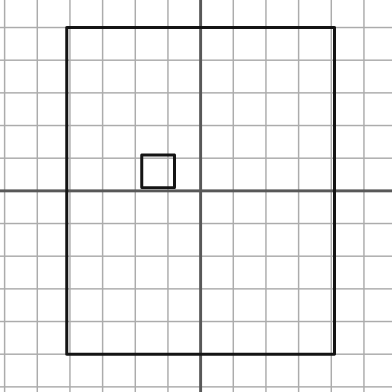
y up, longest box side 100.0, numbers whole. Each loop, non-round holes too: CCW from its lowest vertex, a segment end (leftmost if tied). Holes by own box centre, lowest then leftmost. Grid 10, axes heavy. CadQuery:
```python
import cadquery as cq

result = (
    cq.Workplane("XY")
    .moveTo(-41.0, -50.0)
    .lineTo(41.0, -50.0)
    .lineTo(41.0, 50.0)
    .lineTo(-41.0, 50.0)
    .close()
    .moveTo(-18.0, 1.0)
    .lineTo(-8.0, 1.0)
    .lineTo(-8.0, 11.0)
    .lineTo(-18.0, 11.0)
    .close()
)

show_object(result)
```